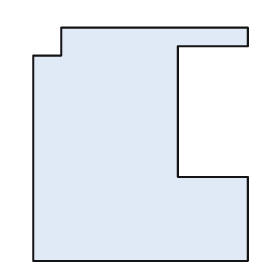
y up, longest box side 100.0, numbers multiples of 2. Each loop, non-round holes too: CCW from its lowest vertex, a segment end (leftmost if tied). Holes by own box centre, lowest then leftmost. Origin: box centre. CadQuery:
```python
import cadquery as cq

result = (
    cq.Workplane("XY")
    .moveTo(-46.0, -50.0)
    .lineTo(46.0, -50.0)
    .lineTo(46.0, -14.0)
    .lineTo(16.0, -14.0)
    .lineTo(16.0, 42.0)
    .lineTo(46.0, 42.0)
    .lineTo(46.0, 50.0)
    .lineTo(-34.0, 50.0)
    .lineTo(-34.0, 38.0)
    .lineTo(-46.0, 38.0)
    .close()
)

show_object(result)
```